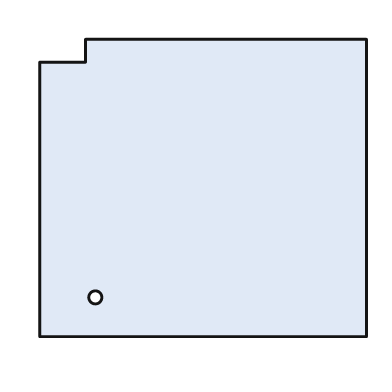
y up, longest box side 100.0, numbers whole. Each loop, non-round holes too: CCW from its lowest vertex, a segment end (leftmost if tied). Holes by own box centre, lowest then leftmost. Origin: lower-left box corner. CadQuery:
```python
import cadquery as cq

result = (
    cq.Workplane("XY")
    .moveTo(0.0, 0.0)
    .lineTo(100.0, 0.0)
    .lineTo(100.0, 91.0)
    .lineTo(14.0, 91.0)
    .lineTo(14.0, 84.0)
    .lineTo(0.0, 84.0)
    .close()
    .moveTo(17.0, 12.0)
    .circle(2.0)
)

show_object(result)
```